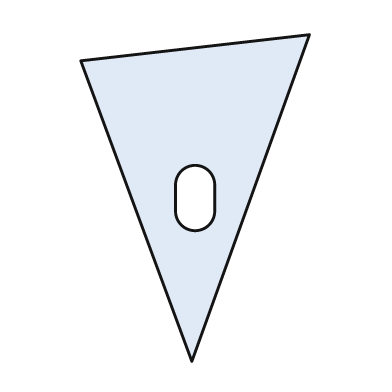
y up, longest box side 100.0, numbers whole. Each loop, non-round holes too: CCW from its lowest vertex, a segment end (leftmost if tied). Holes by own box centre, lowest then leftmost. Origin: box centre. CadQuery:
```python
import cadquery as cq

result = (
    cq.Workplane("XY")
    .moveTo(-1.0, -50.0)
    .lineTo(35.0, 50.0)
    .lineTo(-35.0, 42.0)
    .close()
    .moveTo(-6.0, -4.0)
    .threePointArc((0.0, -10.0), (6.0, -4.0))
    .lineTo(6.0, 4.0)
    .threePointArc((0.0, 10.0), (-6.0, 4.0))
    .close()
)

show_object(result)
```